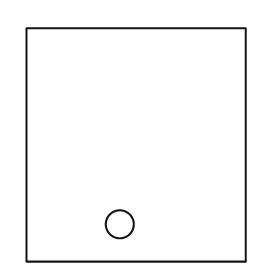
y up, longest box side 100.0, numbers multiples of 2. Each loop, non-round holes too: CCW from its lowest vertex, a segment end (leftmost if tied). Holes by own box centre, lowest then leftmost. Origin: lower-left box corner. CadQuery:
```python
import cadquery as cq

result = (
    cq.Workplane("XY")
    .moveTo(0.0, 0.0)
    .lineTo(94.0, 0.0)
    .lineTo(94.0, 100.0)
    .lineTo(0.0, 100.0)
    .close()
    .moveTo(40.0, 16.0)
    .circle(6.0)
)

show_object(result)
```